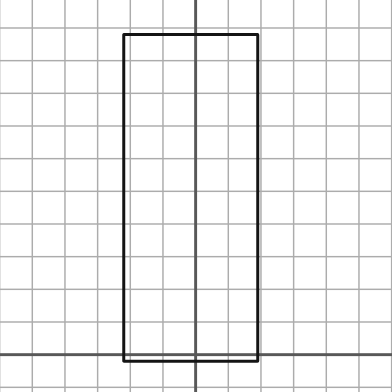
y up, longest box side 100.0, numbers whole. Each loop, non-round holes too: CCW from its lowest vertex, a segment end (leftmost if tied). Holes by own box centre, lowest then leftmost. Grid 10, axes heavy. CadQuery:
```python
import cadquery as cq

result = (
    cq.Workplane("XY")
    .moveTo(-22.0, -2.0)
    .lineTo(19.0, -2.0)
    .lineTo(19.0, 98.0)
    .lineTo(-22.0, 98.0)
    .close()
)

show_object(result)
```